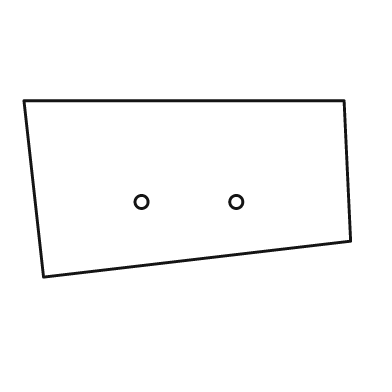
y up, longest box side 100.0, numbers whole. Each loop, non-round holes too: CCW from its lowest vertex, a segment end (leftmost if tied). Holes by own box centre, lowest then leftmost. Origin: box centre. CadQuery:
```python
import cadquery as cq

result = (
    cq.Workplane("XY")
    .moveTo(-44.0, -27.0)
    .lineTo(50.0, -16.0)
    .lineTo(48.0, 27.0)
    .lineTo(-50.0, 27.0)
    .close()
    .moveTo(-14.0, -4.0)
    .circle(2.0)
    .moveTo(15.0, -4.0)
    .circle(2.0)
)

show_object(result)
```